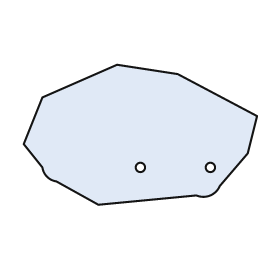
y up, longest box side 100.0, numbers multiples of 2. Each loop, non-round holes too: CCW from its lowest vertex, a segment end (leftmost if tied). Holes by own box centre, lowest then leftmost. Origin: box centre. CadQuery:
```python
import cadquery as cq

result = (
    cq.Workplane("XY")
    .moveTo(-18.0, -30.0)
    .lineTo(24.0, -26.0)
    .threePointArc((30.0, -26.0), (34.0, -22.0))
    .lineTo(46.0, -8.0)
    .lineTo(50.0, 8.0)
    .lineTo(16.0, 26.0)
    .lineTo(-10.0, 30.0)
    .lineTo(-42.0, 16.0)
    .lineTo(-50.0, -4.0)
    .lineTo(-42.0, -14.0)
    .threePointArc((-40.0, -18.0), (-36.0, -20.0))
    .close()
    .moveTo(0.0, -14.0)
    .circle(2.0)
    .moveTo(30.0, -14.0)
    .circle(2.0)
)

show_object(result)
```